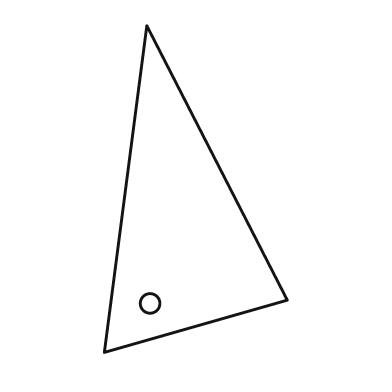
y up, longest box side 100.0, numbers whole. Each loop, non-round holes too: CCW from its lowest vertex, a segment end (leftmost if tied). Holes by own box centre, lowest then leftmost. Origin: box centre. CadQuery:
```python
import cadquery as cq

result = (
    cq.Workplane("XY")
    .moveTo(-28.0, -50.0)
    .lineTo(28.0, -34.0)
    .lineTo(-15.0, 50.0)
    .close()
    .moveTo(-14.0, -35.0)
    .circle(3.0)
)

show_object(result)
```